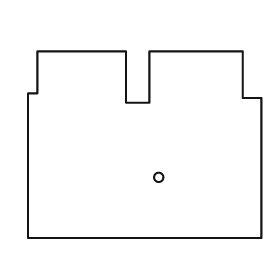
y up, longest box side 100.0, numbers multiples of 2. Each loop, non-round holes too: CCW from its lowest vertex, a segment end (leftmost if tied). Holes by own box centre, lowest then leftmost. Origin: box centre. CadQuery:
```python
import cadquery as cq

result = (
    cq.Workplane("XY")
    .moveTo(-50.0, -40.0)
    .lineTo(50.0, -40.0)
    .lineTo(50.0, 20.0)
    .lineTo(42.0, 20.0)
    .lineTo(42.0, 40.0)
    .lineTo(2.0, 40.0)
    .lineTo(2.0, 18.0)
    .lineTo(-8.0, 18.0)
    .lineTo(-8.0, 40.0)
    .lineTo(-46.0, 40.0)
    .lineTo(-46.0, 22.0)
    .lineTo(-50.0, 22.0)
    .close()
    .moveTo(6.0, -14.0)
    .circle(2.0)
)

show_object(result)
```